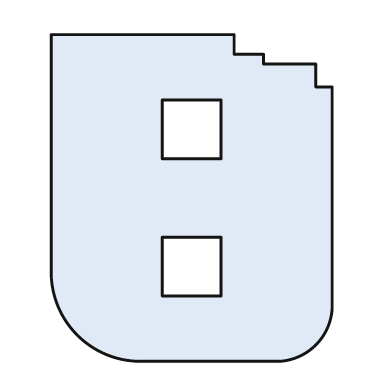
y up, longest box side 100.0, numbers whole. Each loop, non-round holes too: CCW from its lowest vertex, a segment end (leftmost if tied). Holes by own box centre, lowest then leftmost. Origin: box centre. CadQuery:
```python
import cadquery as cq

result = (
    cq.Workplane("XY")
    .moveTo(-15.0, -50.0)
    .lineTo(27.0, -50.0)
    .threePointArc((38.0, -45.0), (43.0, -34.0))
    .lineTo(43.0, 34.0)
    .lineTo(38.0, 34.0)
    .lineTo(38.0, 41.0)
    .lineTo(22.0, 41.0)
    .lineTo(22.0, 44.0)
    .lineTo(13.0, 44.0)
    .lineTo(13.0, 50.0)
    .lineTo(-43.0, 50.0)
    .lineTo(-43.0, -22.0)
    .threePointArc((-35.0, -42.0), (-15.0, -50.0))
    .close()
    .moveTo(-9.0, -30.0)
    .lineTo(9.0, -30.0)
    .lineTo(9.0, -12.0)
    .lineTo(-9.0, -12.0)
    .close()
    .moveTo(-9.0, 12.0)
    .lineTo(9.0, 12.0)
    .lineTo(9.0, 30.0)
    .lineTo(-9.0, 30.0)
    .close()
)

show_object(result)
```